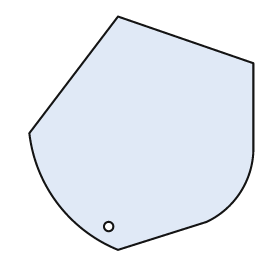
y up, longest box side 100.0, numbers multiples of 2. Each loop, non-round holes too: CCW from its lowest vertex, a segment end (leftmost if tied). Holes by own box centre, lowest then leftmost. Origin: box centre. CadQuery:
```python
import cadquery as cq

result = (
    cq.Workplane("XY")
    .moveTo(-10.0, -50.0)
    .lineTo(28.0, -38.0)
    .threePointArc((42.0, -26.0), (48.0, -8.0))
    .lineTo(48.0, 30.0)
    .lineTo(-10.0, 50.0)
    .lineTo(-48.0, 0.0)
    .threePointArc((-36.0, -30.0), (-10.0, -50.0))
    .close()
    .moveTo(-14.0, -40.0)
    .circle(2.0)
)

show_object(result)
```